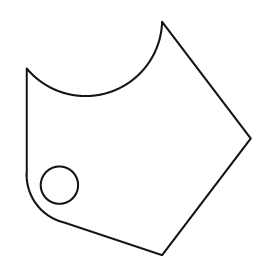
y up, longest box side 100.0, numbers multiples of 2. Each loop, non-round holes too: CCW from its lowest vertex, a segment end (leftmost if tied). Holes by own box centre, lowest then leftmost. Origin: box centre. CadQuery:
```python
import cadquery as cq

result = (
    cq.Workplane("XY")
    .moveTo(10.0, -50.0)
    .lineTo(48.0, 0.0)
    .lineTo(10.0, 50.0)
    .threePointArc((-12.0, 20.0), (-48.0, 30.0))
    .lineTo(-48.0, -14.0)
    .threePointArc((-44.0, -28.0), (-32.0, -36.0))
    .close()
    .moveTo(-34.0, -20.0)
    .circle(8.0)
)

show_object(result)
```